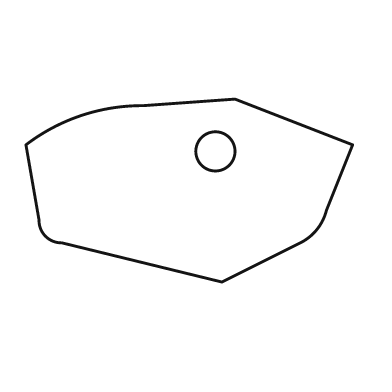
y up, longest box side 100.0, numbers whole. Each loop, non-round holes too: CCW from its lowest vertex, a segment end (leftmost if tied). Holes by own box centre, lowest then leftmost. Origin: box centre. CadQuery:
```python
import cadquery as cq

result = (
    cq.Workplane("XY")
    .moveTo(10.0, -28.0)
    .lineTo(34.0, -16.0)
    .threePointArc((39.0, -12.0), (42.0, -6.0))
    .lineTo(50.0, 14.0)
    .lineTo(14.0, 28.0)
    .lineTo(-14.0, 26.0)
    .threePointArc((-33.0, 23.0), (-50.0, 14.0))
    .lineTo(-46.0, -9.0)
    .threePointArc((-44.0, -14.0), (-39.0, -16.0))
    .close()
    .moveTo(8.0, 12.0)
    .circle(6.0)
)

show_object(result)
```